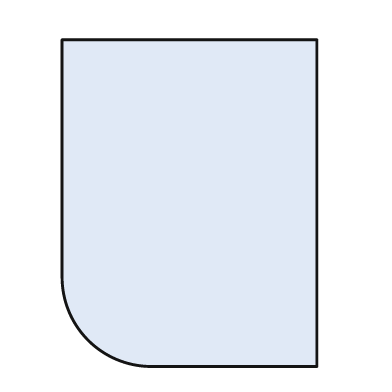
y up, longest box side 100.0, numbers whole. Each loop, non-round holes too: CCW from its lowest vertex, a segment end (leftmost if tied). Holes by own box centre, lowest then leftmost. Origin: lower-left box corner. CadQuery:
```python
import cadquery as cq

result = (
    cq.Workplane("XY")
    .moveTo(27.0, 0.0)
    .lineTo(78.0, 0.0)
    .lineTo(78.0, 100.0)
    .lineTo(0.0, 100.0)
    .lineTo(0.0, 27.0)
    .threePointArc((8.0, 8.0), (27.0, 0.0))
    .close()
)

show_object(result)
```